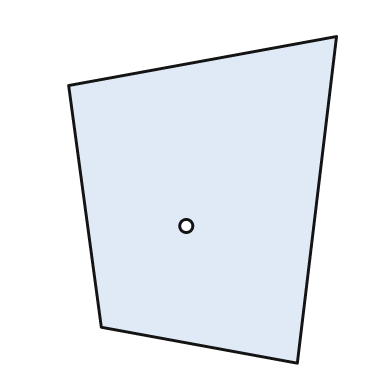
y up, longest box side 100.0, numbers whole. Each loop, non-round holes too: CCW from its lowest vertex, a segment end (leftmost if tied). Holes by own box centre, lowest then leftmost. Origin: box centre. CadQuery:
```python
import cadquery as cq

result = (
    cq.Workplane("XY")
    .moveTo(29.0, -50.0)
    .lineTo(41.0, 50.0)
    .lineTo(-41.0, 35.0)
    .lineTo(-31.0, -39.0)
    .close()
    .moveTo(-5.0, -8.0)
    .circle(2.0)
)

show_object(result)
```